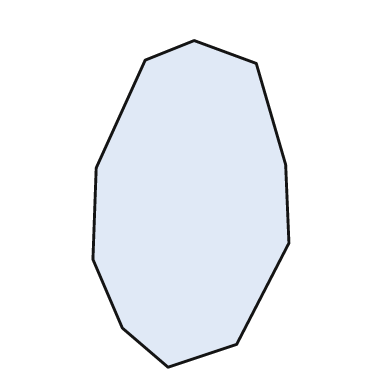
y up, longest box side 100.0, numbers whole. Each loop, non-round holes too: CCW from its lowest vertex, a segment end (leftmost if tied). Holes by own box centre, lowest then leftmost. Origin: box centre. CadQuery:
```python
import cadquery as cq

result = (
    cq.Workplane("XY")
    .moveTo(-7.0, -50.0)
    .lineTo(14.0, -43.0)
    .lineTo(30.0, -12.0)
    .lineTo(29.0, 12.0)
    .lineTo(20.0, 43.0)
    .lineTo(1.0, 50.0)
    .lineTo(-14.0, 44.0)
    .lineTo(-29.0, 11.0)
    .lineTo(-30.0, -17.0)
    .lineTo(-21.0, -38.0)
    .close()
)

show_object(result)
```